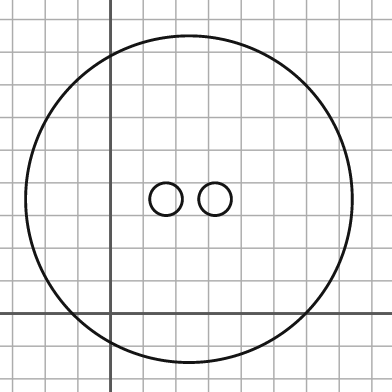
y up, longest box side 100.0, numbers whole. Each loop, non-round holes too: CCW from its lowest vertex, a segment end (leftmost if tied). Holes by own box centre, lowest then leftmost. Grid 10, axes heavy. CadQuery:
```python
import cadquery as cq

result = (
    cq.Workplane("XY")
    .moveTo(24.0, 35.0)
    .circle(50.0)
    .moveTo(17.0, 35.0)
    .circle(5.0)
    .moveTo(32.0, 35.0)
    .circle(5.0)
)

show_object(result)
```